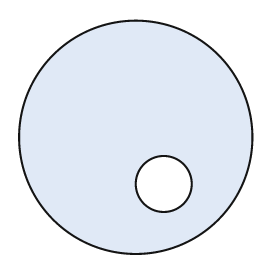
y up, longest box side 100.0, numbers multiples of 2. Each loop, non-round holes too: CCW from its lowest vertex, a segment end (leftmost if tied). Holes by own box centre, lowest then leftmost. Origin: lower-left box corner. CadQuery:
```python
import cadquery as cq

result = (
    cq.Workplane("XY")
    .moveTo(50.0, 50.0)
    .circle(50.0)
    .moveTo(62.0, 30.0)
    .circle(12.0)
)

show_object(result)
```